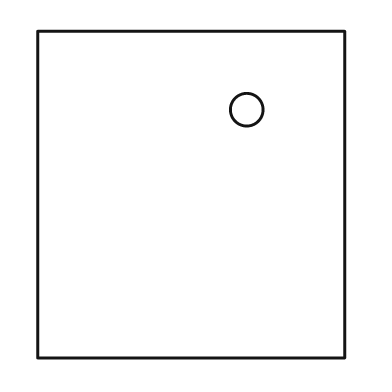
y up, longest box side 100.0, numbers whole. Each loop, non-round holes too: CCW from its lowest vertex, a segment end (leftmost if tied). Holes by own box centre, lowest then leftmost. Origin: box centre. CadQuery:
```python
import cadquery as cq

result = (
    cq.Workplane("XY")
    .moveTo(-47.0, -50.0)
    .lineTo(47.0, -50.0)
    .lineTo(47.0, 50.0)
    .lineTo(-47.0, 50.0)
    .close()
    .moveTo(17.0, 26.0)
    .circle(5.0)
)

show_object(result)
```